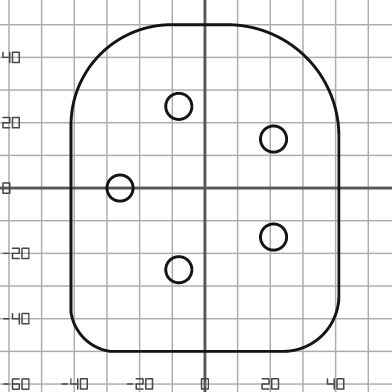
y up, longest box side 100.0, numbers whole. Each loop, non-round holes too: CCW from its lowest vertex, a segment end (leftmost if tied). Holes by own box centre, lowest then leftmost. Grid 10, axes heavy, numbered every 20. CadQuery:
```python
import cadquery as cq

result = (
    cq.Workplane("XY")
    .moveTo(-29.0, -50.0)
    .lineTo(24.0, -50.0)
    .threePointArc((36.0, -45.0), (41.0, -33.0))
    .lineTo(41.0, 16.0)
    .threePointArc((31.0, 40.0), (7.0, 50.0))
    .lineTo(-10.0, 50.0)
    .threePointArc((-32.0, 41.0), (-41.0, 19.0))
    .lineTo(-41.0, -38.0)
    .threePointArc((-37.0, -46.0), (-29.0, -50.0))
    .close()
    .moveTo(-8.0, -25.0)
    .circle(4.0)
    .moveTo(21.0, -15.0)
    .circle(4.0)
    .moveTo(-26.0, 0.0)
    .circle(4.0)
    .moveTo(21.0, 15.0)
    .circle(4.0)
    .moveTo(-8.0, 25.0)
    .circle(4.0)
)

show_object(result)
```